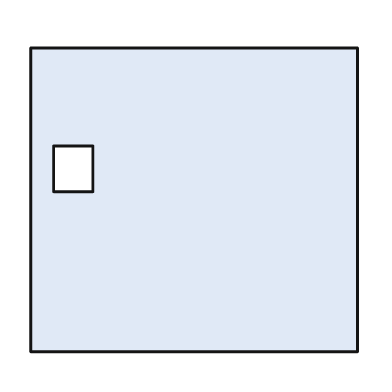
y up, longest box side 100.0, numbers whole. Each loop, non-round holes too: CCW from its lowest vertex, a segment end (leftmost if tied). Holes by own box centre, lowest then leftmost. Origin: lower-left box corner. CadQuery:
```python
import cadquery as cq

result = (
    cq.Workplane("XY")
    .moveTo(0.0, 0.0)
    .lineTo(100.0, 0.0)
    .lineTo(100.0, 93.0)
    .lineTo(0.0, 93.0)
    .close()
    .moveTo(7.0, 49.0)
    .lineTo(19.0, 49.0)
    .lineTo(19.0, 63.0)
    .lineTo(7.0, 63.0)
    .close()
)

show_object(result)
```